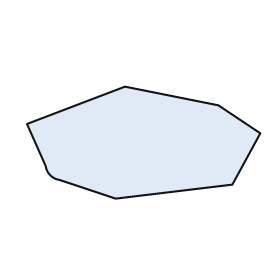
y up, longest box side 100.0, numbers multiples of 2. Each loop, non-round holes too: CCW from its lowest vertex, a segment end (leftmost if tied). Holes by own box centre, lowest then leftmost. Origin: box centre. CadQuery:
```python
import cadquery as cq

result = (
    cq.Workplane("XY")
    .moveTo(-12.0, -24.0)
    .lineTo(38.0, -18.0)
    .lineTo(50.0, 4.0)
    .lineTo(32.0, 16.0)
    .lineTo(-8.0, 24.0)
    .lineTo(-50.0, 8.0)
    .lineTo(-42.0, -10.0)
    .threePointArc((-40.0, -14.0), (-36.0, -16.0))
    .close()
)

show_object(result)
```